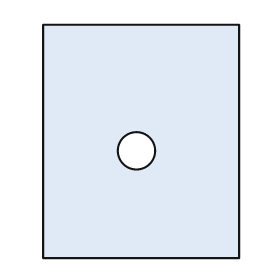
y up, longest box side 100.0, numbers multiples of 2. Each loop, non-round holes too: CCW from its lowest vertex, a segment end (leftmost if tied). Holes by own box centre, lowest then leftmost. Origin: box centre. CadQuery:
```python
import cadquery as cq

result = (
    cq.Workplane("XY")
    .moveTo(-42.0, -50.0)
    .lineTo(42.0, -50.0)
    .lineTo(42.0, 50.0)
    .lineTo(-42.0, 50.0)
    .close()
    .moveTo(-2.0, -4.0)
    .circle(8.0)
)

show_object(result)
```